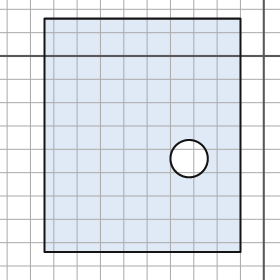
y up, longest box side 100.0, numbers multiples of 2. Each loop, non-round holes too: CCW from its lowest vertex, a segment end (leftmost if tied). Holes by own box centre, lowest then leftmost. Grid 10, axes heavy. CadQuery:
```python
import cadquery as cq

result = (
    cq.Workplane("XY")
    .moveTo(-94.0, -84.0)
    .lineTo(-10.0, -84.0)
    .lineTo(-10.0, 16.0)
    .lineTo(-94.0, 16.0)
    .close()
    .moveTo(-32.0, -44.0)
    .circle(8.0)
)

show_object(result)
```